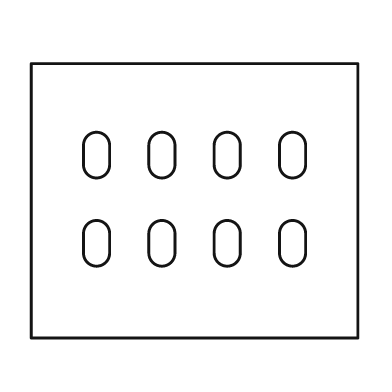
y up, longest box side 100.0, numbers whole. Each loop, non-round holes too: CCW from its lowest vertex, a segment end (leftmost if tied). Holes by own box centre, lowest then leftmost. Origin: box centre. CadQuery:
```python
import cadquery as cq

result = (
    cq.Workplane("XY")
    .moveTo(-50.0, -42.0)
    .lineTo(50.0, -42.0)
    .lineTo(50.0, 42.0)
    .lineTo(-50.0, 42.0)
    .close()
    .moveTo(-34.0, -16.0)
    .threePointArc((-30.0, -20.0), (-26.0, -16.0))
    .lineTo(-26.0, -10.0)
    .threePointArc((-30.0, -6.0), (-34.0, -10.0))
    .close()
    .moveTo(-14.0, -16.0)
    .threePointArc((-10.0, -20.0), (-6.0, -16.0))
    .lineTo(-6.0, -10.0)
    .threePointArc((-10.0, -6.0), (-14.0, -10.0))
    .close()
    .moveTo(6.0, -16.0)
    .threePointArc((10.0, -20.0), (14.0, -16.0))
    .lineTo(14.0, -10.0)
    .threePointArc((10.0, -6.0), (6.0, -10.0))
    .close()
    .moveTo(26.0, -16.0)
    .threePointArc((30.0, -20.0), (34.0, -16.0))
    .lineTo(34.0, -10.0)
    .threePointArc((30.0, -6.0), (26.0, -10.0))
    .close()
    .moveTo(-34.0, 11.0)
    .threePointArc((-30.0, 7.0), (-26.0, 11.0))
    .lineTo(-26.0, 17.0)
    .threePointArc((-30.0, 21.0), (-34.0, 17.0))
    .close()
    .moveTo(-14.0, 11.0)
    .threePointArc((-10.0, 7.0), (-6.0, 11.0))
    .lineTo(-6.0, 17.0)
    .threePointArc((-10.0, 21.0), (-14.0, 17.0))
    .close()
    .moveTo(6.0, 11.0)
    .threePointArc((10.0, 7.0), (14.0, 11.0))
    .lineTo(14.0, 17.0)
    .threePointArc((10.0, 21.0), (6.0, 17.0))
    .close()
    .moveTo(26.0, 11.0)
    .threePointArc((30.0, 7.0), (34.0, 11.0))
    .lineTo(34.0, 17.0)
    .threePointArc((30.0, 21.0), (26.0, 17.0))
    .close()
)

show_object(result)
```